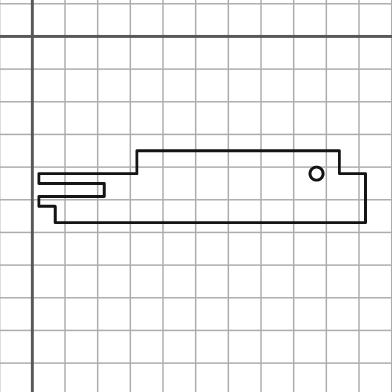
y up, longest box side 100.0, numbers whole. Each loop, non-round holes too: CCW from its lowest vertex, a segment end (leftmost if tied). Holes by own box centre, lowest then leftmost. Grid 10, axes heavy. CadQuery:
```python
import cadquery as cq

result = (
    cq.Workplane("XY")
    .moveTo(7.0, -57.0)
    .lineTo(102.0, -57.0)
    .lineTo(102.0, -42.0)
    .lineTo(94.0, -42.0)
    .lineTo(94.0, -35.0)
    .lineTo(32.0, -35.0)
    .lineTo(32.0, -42.0)
    .lineTo(2.0, -42.0)
    .lineTo(2.0, -45.0)
    .lineTo(22.0, -45.0)
    .lineTo(22.0, -49.0)
    .lineTo(2.0, -49.0)
    .lineTo(2.0, -52.0)
    .lineTo(7.0, -52.0)
    .close()
    .moveTo(87.0, -42.0)
    .circle(2.0)
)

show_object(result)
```